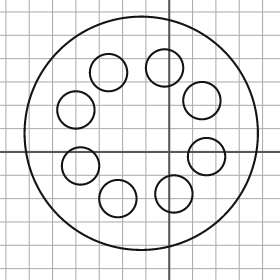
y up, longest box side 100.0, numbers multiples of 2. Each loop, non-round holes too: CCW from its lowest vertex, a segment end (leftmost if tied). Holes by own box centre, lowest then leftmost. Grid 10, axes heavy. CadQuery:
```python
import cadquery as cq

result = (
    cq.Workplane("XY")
    .moveTo(-12.0, 8.0)
    .circle(50.0)
    .moveTo(-22.0, -20.0)
    .circle(8.0)
    .moveTo(2.0, -18.0)
    .circle(8.0)
    .moveTo(-38.0, -6.0)
    .circle(8.0)
    .moveTo(16.0, -2.0)
    .circle(8.0)
    .moveTo(-40.0, 18.0)
    .circle(8.0)
    .moveTo(14.0, 22.0)
    .circle(8.0)
    .moveTo(-26.0, 34.0)
    .circle(8.0)
    .moveTo(-2.0, 36.0)
    .circle(8.0)
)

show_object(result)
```